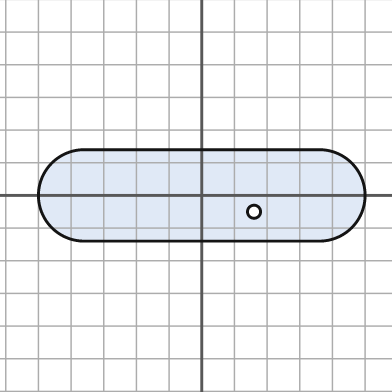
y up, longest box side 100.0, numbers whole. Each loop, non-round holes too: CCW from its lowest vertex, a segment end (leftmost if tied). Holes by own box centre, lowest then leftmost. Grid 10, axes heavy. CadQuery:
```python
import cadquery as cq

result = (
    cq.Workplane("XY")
    .moveTo(-36.0, -14.0)
    .lineTo(36.0, -14.0)
    .threePointArc((50.0, 0.0), (36.0, 14.0))
    .lineTo(-36.0, 14.0)
    .threePointArc((-50.0, 0.0), (-36.0, -14.0))
    .close()
    .moveTo(16.0, -5.0)
    .circle(2.0)
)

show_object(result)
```